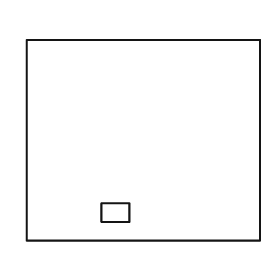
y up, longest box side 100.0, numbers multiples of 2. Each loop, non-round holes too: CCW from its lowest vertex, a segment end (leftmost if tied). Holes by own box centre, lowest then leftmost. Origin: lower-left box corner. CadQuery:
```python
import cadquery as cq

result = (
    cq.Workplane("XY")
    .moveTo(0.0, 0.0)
    .lineTo(100.0, 0.0)
    .lineTo(100.0, 86.0)
    .lineTo(0.0, 86.0)
    .close()
    .moveTo(32.0, 8.0)
    .lineTo(44.0, 8.0)
    .lineTo(44.0, 16.0)
    .lineTo(32.0, 16.0)
    .close()
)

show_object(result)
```